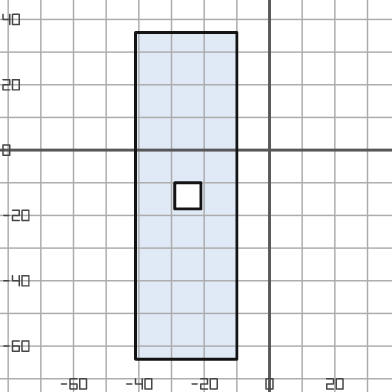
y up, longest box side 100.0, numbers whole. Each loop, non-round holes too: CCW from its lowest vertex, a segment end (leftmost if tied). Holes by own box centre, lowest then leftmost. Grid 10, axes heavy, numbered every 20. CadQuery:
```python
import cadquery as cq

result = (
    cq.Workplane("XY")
    .moveTo(-41.0, -64.0)
    .lineTo(-10.0, -64.0)
    .lineTo(-10.0, 36.0)
    .lineTo(-41.0, 36.0)
    .close()
    .moveTo(-29.0, -18.0)
    .lineTo(-21.0, -18.0)
    .lineTo(-21.0, -10.0)
    .lineTo(-29.0, -10.0)
    .close()
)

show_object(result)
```